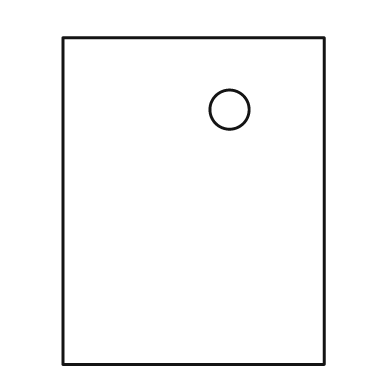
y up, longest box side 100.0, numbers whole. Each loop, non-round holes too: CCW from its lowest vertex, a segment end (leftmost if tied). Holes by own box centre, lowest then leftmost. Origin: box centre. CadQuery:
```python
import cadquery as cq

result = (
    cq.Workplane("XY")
    .moveTo(-40.0, -50.0)
    .lineTo(40.0, -50.0)
    .lineTo(40.0, 50.0)
    .lineTo(-40.0, 50.0)
    .close()
    .moveTo(11.0, 28.0)
    .circle(6.0)
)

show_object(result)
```